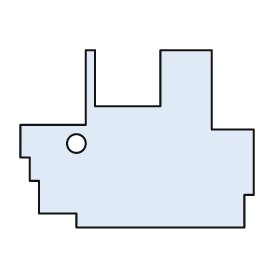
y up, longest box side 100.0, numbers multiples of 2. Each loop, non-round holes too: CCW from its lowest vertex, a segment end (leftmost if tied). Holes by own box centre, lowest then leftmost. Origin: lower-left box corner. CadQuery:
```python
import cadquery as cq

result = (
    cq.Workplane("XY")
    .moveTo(24.0, 0.0)
    .lineTo(96.0, 0.0)
    .lineTo(96.0, 14.0)
    .lineTo(100.0, 14.0)
    .lineTo(100.0, 42.0)
    .lineTo(82.0, 42.0)
    .lineTo(82.0, 76.0)
    .lineTo(60.0, 76.0)
    .lineTo(60.0, 52.0)
    .lineTo(32.0, 52.0)
    .lineTo(32.0, 76.0)
    .lineTo(28.0, 76.0)
    .lineTo(28.0, 44.0)
    .lineTo(0.0, 44.0)
    .lineTo(0.0, 30.0)
    .lineTo(4.0, 30.0)
    .lineTo(4.0, 20.0)
    .lineTo(8.0, 20.0)
    .lineTo(8.0, 6.0)
    .lineTo(24.0, 6.0)
    .close()
    .moveTo(24.0, 36.0)
    .circle(4.0)
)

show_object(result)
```